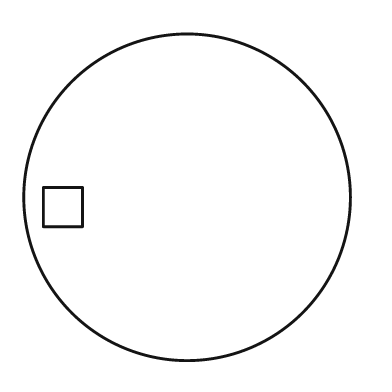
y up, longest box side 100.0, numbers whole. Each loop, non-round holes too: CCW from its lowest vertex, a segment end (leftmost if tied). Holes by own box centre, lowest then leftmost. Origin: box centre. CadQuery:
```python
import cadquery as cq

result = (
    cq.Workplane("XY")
    .moveTo(0.0, 0.0)
    .circle(50.0)
    .moveTo(-44.0, -9.0)
    .lineTo(-32.0, -9.0)
    .lineTo(-32.0, 3.0)
    .lineTo(-44.0, 3.0)
    .close()
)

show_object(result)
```